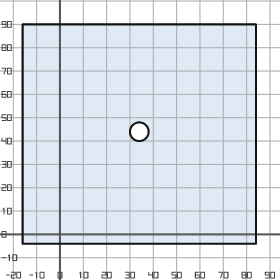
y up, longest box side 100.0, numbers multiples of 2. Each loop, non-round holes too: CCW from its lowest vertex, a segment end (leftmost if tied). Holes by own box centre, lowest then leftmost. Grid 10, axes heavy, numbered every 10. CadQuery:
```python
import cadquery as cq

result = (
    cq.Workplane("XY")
    .moveTo(-16.0, -4.0)
    .lineTo(84.0, -4.0)
    .lineTo(84.0, 90.0)
    .lineTo(-16.0, 90.0)
    .close()
    .moveTo(34.0, 44.0)
    .circle(4.0)
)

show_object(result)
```